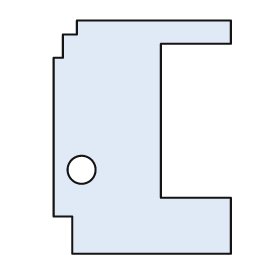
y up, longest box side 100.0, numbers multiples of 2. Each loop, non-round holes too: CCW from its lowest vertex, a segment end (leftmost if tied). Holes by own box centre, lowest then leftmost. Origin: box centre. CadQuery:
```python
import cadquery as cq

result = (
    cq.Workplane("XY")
    .moveTo(-30.0, -50.0)
    .lineTo(38.0, -50.0)
    .lineTo(38.0, -26.0)
    .lineTo(8.0, -26.0)
    .lineTo(8.0, 40.0)
    .lineTo(38.0, 40.0)
    .lineTo(38.0, 50.0)
    .lineTo(-28.0, 50.0)
    .lineTo(-28.0, 44.0)
    .lineTo(-34.0, 44.0)
    .lineTo(-34.0, 34.0)
    .lineTo(-38.0, 34.0)
    .lineTo(-38.0, -34.0)
    .lineTo(-30.0, -34.0)
    .close()
    .moveTo(-26.0, -14.0)
    .circle(6.0)
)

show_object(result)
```